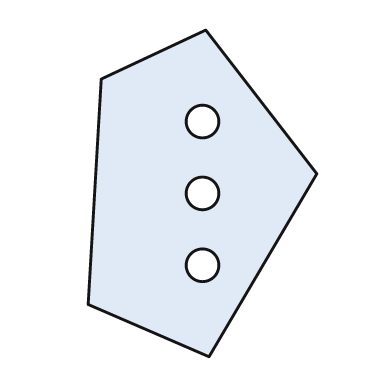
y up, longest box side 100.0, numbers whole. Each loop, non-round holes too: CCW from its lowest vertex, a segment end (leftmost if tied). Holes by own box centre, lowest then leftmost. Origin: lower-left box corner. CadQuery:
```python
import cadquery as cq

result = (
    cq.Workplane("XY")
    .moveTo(37.0, 0.0)
    .lineTo(70.0, 56.0)
    .lineTo(36.0, 100.0)
    .lineTo(4.0, 85.0)
    .lineTo(0.0, 16.0)
    .close()
    .moveTo(35.0, 28.0)
    .circle(5.0)
    .moveTo(35.0, 50.0)
    .circle(5.0)
    .moveTo(35.0, 72.0)
    .circle(5.0)
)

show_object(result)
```